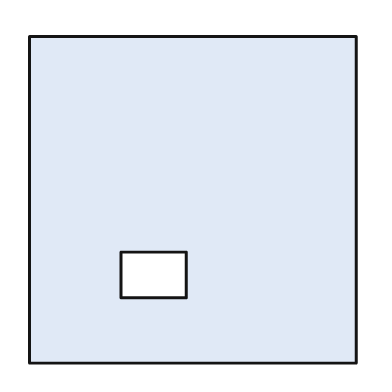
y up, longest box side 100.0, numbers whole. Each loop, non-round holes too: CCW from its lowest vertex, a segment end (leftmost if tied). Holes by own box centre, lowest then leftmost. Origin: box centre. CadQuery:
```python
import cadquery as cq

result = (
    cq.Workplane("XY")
    .moveTo(-50.0, -50.0)
    .lineTo(50.0, -50.0)
    .lineTo(50.0, 50.0)
    .lineTo(-50.0, 50.0)
    .close()
    .moveTo(-22.0, -30.0)
    .lineTo(-2.0, -30.0)
    .lineTo(-2.0, -16.0)
    .lineTo(-22.0, -16.0)
    .close()
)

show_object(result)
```